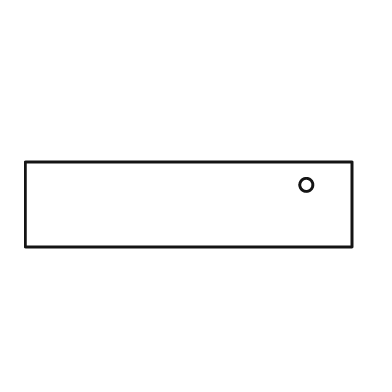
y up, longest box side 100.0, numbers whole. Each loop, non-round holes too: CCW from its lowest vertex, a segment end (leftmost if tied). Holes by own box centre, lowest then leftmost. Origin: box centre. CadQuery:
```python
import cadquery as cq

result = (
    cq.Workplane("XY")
    .moveTo(-50.0, -13.0)
    .lineTo(50.0, -13.0)
    .lineTo(50.0, 13.0)
    .lineTo(-50.0, 13.0)
    .close()
    .moveTo(36.0, 6.0)
    .circle(2.0)
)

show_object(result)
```